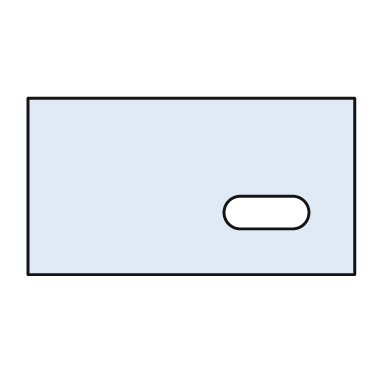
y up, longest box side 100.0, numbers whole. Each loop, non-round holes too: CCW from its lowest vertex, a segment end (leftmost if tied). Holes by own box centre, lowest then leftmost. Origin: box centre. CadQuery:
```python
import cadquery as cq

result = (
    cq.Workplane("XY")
    .moveTo(-50.0, -27.0)
    .lineTo(50.0, -27.0)
    .lineTo(50.0, 27.0)
    .lineTo(-50.0, 27.0)
    .close()
    .moveTo(15.0, -13.0)
    .lineTo(31.0, -13.0)
    .threePointArc((36.0, -8.0), (31.0, -3.0))
    .lineTo(15.0, -3.0)
    .threePointArc((10.0, -8.0), (15.0, -13.0))
    .close()
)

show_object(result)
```